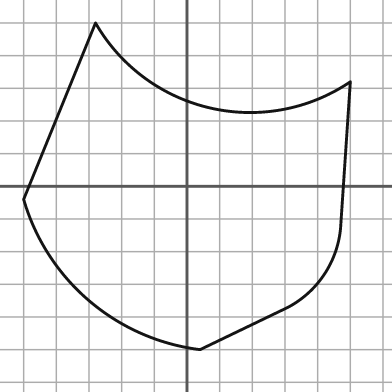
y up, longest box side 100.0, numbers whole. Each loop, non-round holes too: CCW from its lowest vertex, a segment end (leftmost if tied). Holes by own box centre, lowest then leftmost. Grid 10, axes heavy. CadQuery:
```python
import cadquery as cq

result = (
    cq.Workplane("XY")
    .moveTo(4.0, -50.0)
    .lineTo(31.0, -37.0)
    .threePointArc((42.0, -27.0), (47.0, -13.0))
    .lineTo(50.0, 32.0)
    .threePointArc((7.0, 24.0), (-28.0, 50.0))
    .lineTo(-50.0, -4.0)
    .threePointArc((-30.0, -35.0), (4.0, -50.0))
    .close()
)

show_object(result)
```